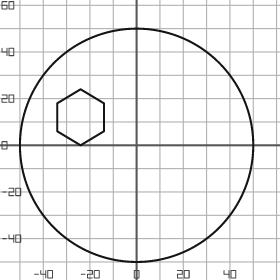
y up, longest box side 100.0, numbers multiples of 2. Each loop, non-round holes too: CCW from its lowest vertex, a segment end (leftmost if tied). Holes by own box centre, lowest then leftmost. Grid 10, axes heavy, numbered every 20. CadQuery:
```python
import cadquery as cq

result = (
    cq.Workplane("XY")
    .moveTo(0.0, 0.0)
    .circle(50.0)
    .moveTo(-24.0, 0.0)
    .lineTo(-14.0, 6.0)
    .lineTo(-14.0, 18.0)
    .lineTo(-24.0, 24.0)
    .lineTo(-34.0, 18.0)
    .lineTo(-34.0, 6.0)
    .close()
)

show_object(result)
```